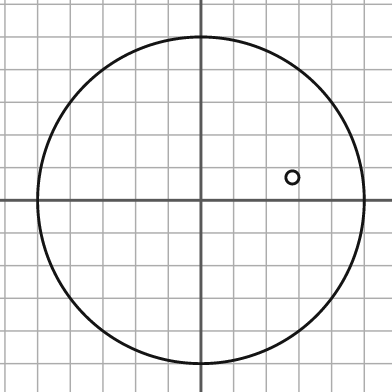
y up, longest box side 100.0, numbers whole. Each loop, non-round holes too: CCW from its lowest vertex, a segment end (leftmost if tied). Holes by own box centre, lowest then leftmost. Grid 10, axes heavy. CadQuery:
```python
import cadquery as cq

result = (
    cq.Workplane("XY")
    .moveTo(0.0, 0.0)
    .circle(50.0)
    .moveTo(28.0, 7.0)
    .circle(2.0)
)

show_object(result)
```